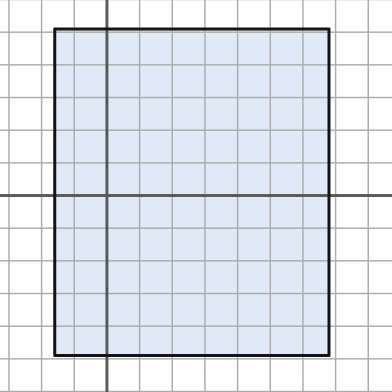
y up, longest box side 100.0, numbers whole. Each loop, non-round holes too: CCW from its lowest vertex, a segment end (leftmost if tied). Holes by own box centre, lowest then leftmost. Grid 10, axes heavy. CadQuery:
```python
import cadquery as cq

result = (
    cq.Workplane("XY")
    .moveTo(-16.0, -49.0)
    .lineTo(68.0, -49.0)
    .lineTo(68.0, 51.0)
    .lineTo(-16.0, 51.0)
    .close()
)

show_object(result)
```